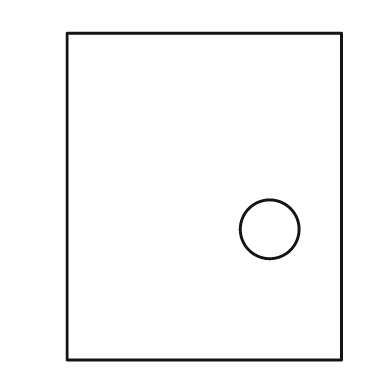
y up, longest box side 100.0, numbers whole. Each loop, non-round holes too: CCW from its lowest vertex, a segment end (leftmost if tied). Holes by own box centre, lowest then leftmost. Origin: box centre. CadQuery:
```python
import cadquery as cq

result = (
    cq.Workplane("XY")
    .moveTo(-42.0, -50.0)
    .lineTo(42.0, -50.0)
    .lineTo(42.0, 50.0)
    .lineTo(-42.0, 50.0)
    .close()
    .moveTo(20.0, -10.0)
    .circle(9.0)
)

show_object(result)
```